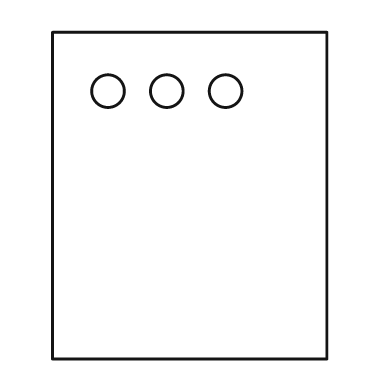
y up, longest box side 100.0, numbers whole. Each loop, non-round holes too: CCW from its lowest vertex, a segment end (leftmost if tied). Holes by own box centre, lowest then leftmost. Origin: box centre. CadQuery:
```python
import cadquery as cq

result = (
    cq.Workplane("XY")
    .moveTo(-42.0, -50.0)
    .lineTo(42.0, -50.0)
    .lineTo(42.0, 50.0)
    .lineTo(-42.0, 50.0)
    .close()
    .moveTo(-25.0, 32.0)
    .circle(5.0)
    .moveTo(-7.0, 32.0)
    .circle(5.0)
    .moveTo(11.0, 32.0)
    .circle(5.0)
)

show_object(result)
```